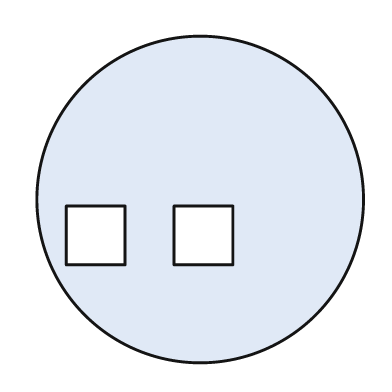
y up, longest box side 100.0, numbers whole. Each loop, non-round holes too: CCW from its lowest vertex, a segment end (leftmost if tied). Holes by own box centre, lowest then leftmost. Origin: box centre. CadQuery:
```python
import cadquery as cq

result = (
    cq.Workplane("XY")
    .moveTo(0.0, 0.0)
    .circle(50.0)
    .moveTo(-41.0, -20.0)
    .lineTo(-23.0, -20.0)
    .lineTo(-23.0, -2.0)
    .lineTo(-41.0, -2.0)
    .close()
    .moveTo(-8.0, -20.0)
    .lineTo(10.0, -20.0)
    .lineTo(10.0, -2.0)
    .lineTo(-8.0, -2.0)
    .close()
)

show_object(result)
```